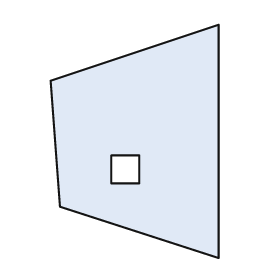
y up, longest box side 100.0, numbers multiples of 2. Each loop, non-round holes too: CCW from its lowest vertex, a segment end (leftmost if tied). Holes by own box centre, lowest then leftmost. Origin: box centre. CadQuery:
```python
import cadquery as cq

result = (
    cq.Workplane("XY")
    .moveTo(36.0, -50.0)
    .lineTo(36.0, 50.0)
    .lineTo(-36.0, 26.0)
    .lineTo(-32.0, -28.0)
    .close()
    .moveTo(-10.0, -18.0)
    .lineTo(2.0, -18.0)
    .lineTo(2.0, -6.0)
    .lineTo(-10.0, -6.0)
    .close()
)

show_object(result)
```